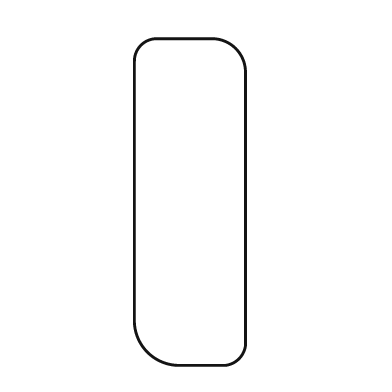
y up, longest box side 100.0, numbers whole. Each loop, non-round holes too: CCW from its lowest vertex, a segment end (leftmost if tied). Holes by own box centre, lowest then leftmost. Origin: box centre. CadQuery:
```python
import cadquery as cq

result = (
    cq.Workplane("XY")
    .moveTo(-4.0, -50.0)
    .lineTo(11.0, -50.0)
    .threePointArc((15.0, -48.0), (17.0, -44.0))
    .lineTo(17.0, 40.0)
    .threePointArc((14.0, 47.0), (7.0, 50.0))
    .lineTo(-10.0, 50.0)
    .threePointArc((-15.0, 48.0), (-17.0, 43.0))
    .lineTo(-17.0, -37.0)
    .threePointArc((-13.0, -46.0), (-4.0, -50.0))
    .close()
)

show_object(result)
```